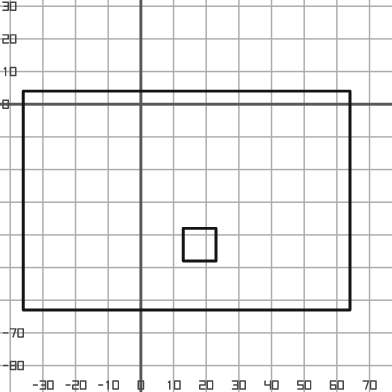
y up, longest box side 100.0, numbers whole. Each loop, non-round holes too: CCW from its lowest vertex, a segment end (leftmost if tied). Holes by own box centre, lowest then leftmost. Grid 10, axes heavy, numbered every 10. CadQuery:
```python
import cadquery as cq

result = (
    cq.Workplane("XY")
    .moveTo(-36.0, -63.0)
    .lineTo(64.0, -63.0)
    .lineTo(64.0, 4.0)
    .lineTo(-36.0, 4.0)
    .close()
    .moveTo(13.0, -48.0)
    .lineTo(23.0, -48.0)
    .lineTo(23.0, -38.0)
    .lineTo(13.0, -38.0)
    .close()
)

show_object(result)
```